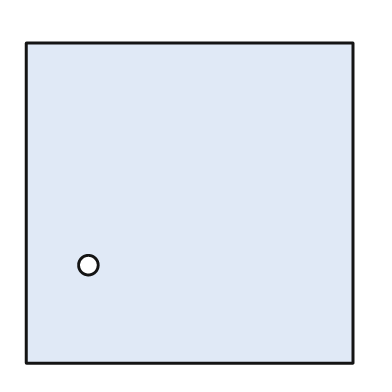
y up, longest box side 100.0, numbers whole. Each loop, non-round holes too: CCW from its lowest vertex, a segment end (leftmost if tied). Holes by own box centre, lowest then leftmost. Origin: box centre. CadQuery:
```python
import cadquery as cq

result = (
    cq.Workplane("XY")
    .moveTo(-50.0, -49.0)
    .lineTo(50.0, -49.0)
    .lineTo(50.0, 49.0)
    .lineTo(-50.0, 49.0)
    .close()
    .moveTo(-31.0, -19.0)
    .circle(3.0)
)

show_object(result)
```